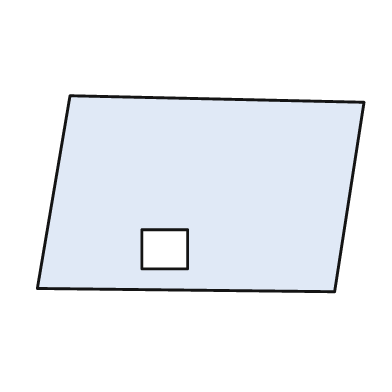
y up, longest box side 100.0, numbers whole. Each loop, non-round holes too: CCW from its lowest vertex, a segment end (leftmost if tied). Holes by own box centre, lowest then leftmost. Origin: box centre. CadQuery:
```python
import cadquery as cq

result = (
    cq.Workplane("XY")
    .moveTo(41.0, -30.0)
    .lineTo(50.0, 28.0)
    .lineTo(-40.0, 30.0)
    .lineTo(-50.0, -29.0)
    .close()
    .moveTo(-18.0, -23.0)
    .lineTo(-4.0, -23.0)
    .lineTo(-4.0, -11.0)
    .lineTo(-18.0, -11.0)
    .close()
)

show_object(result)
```